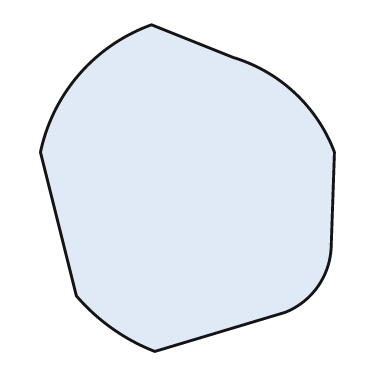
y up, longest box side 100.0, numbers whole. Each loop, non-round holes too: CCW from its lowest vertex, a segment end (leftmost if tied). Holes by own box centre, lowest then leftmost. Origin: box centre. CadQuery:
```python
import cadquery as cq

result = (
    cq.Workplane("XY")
    .moveTo(-10.0, -50.0)
    .lineTo(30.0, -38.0)
    .threePointArc((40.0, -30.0), (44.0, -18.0))
    .lineTo(45.0, 11.0)
    .threePointArc((33.0, 29.0), (14.0, 40.0))
    .lineTo(-11.0, 50.0)
    .threePointArc((-33.0, 35.0), (-45.0, 11.0))
    .lineTo(-34.0, -33.0)
    .threePointArc((-23.0, -43.0), (-10.0, -50.0))
    .close()
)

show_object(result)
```